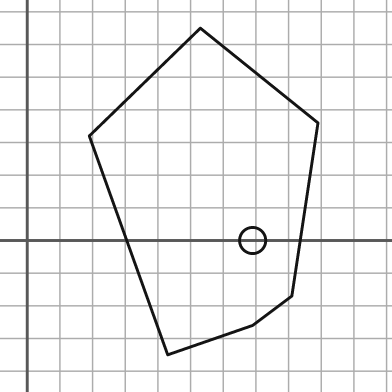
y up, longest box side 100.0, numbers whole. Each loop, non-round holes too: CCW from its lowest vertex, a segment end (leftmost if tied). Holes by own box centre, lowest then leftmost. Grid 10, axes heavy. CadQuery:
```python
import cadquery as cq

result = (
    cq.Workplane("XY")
    .moveTo(43.0, -35.0)
    .lineTo(69.0, -26.0)
    .lineTo(81.0, -17.0)
    .lineTo(89.0, 36.0)
    .lineTo(53.0, 65.0)
    .lineTo(19.0, 32.0)
    .close()
    .moveTo(69.0, 0.0)
    .circle(4.0)
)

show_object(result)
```